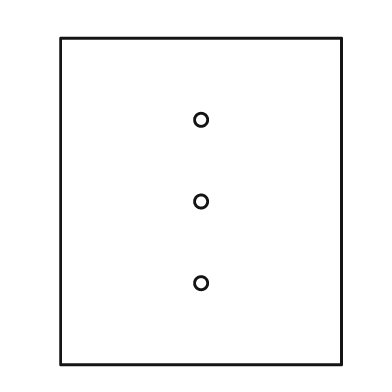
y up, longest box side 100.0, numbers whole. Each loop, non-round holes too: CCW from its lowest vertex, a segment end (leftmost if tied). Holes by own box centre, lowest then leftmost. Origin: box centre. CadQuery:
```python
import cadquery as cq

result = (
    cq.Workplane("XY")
    .moveTo(-43.0, -50.0)
    .lineTo(43.0, -50.0)
    .lineTo(43.0, 50.0)
    .lineTo(-43.0, 50.0)
    .close()
    .moveTo(0.0, -25.0)
    .circle(2.0)
    .moveTo(0.0, 0.0)
    .circle(2.0)
    .moveTo(0.0, 25.0)
    .circle(2.0)
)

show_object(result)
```